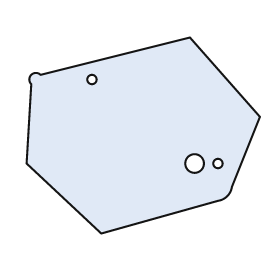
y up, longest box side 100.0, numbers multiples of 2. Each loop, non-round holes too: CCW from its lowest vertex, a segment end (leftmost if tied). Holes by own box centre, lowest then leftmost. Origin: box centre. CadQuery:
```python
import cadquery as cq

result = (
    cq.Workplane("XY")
    .moveTo(-18.0, -42.0)
    .lineTo(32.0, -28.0)
    .threePointArc((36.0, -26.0), (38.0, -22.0))
    .lineTo(50.0, 8.0)
    .lineTo(20.0, 42.0)
    .lineTo(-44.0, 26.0)
    .threePointArc((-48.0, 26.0), (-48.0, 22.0))
    .lineTo(-50.0, -12.0)
    .close()
    .moveTo(22.0, -12.0)
    .circle(4.0)
    .moveTo(32.0, -12.0)
    .circle(2.0)
    .moveTo(-22.0, 24.0)
    .circle(2.0)
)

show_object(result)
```